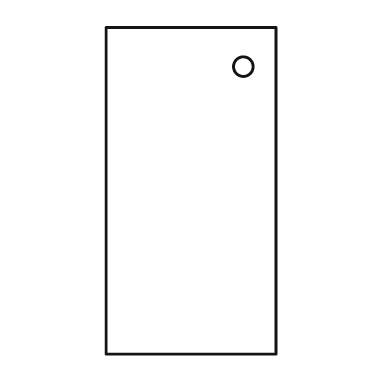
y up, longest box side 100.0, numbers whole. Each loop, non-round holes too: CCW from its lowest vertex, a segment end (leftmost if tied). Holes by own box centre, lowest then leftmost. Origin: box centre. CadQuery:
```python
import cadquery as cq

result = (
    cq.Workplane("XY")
    .moveTo(-26.0, -50.0)
    .lineTo(26.0, -50.0)
    .lineTo(26.0, 50.0)
    .lineTo(-26.0, 50.0)
    .close()
    .moveTo(16.0, 38.0)
    .circle(3.0)
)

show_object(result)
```